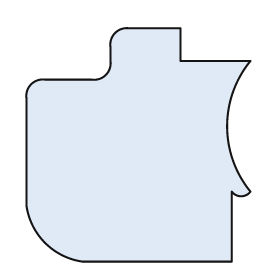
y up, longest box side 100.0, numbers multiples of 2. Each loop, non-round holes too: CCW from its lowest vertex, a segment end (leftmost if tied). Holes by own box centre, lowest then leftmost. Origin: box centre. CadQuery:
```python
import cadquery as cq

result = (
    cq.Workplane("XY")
    .moveTo(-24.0, -50.0)
    .lineTo(40.0, -50.0)
    .lineTo(40.0, -20.0)
    .threePointArc((44.0, -22.0), (48.0, -20.0))
    .threePointArc((38.0, 8.0), (48.0, 36.0))
    .lineTo(18.0, 36.0)
    .lineTo(18.0, 50.0)
    .lineTo(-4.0, 50.0)
    .threePointArc((-10.0, 48.0), (-12.0, 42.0))
    .lineTo(-12.0, 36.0)
    .threePointArc((-14.0, 30.0), (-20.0, 28.0))
    .lineTo(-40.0, 28.0)
    .threePointArc((-46.0, 26.0), (-48.0, 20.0))
    .lineTo(-48.0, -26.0)
    .threePointArc((-40.0, -42.0), (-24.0, -50.0))
    .close()
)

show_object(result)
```